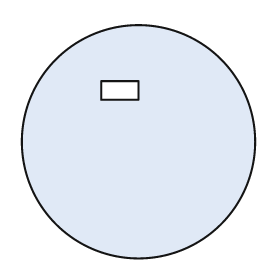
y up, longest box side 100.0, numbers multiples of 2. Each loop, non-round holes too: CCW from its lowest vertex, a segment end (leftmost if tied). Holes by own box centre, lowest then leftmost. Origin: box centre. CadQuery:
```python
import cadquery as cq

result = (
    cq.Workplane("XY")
    .moveTo(0.0, 0.0)
    .circle(50.0)
    .moveTo(-16.0, 18.0)
    .lineTo(0.0, 18.0)
    .lineTo(0.0, 26.0)
    .lineTo(-16.0, 26.0)
    .close()
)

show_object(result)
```